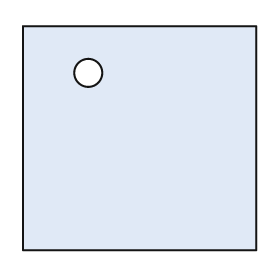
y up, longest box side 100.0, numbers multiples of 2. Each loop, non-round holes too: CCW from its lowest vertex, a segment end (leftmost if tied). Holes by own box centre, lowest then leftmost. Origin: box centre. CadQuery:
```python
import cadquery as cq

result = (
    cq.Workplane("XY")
    .moveTo(-50.0, -48.0)
    .lineTo(50.0, -48.0)
    .lineTo(50.0, 48.0)
    .lineTo(-50.0, 48.0)
    .close()
    .moveTo(-22.0, 28.0)
    .circle(6.0)
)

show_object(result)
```